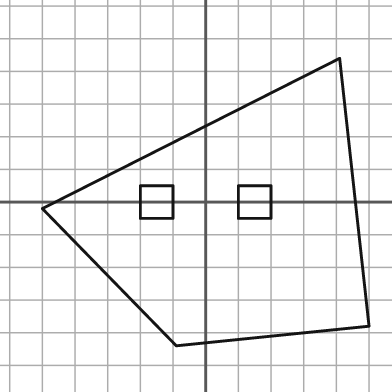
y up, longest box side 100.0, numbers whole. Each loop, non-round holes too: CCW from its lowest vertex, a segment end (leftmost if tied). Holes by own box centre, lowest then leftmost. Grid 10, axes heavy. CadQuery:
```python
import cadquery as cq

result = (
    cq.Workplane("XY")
    .moveTo(-9.0, -44.0)
    .lineTo(50.0, -38.0)
    .lineTo(41.0, 44.0)
    .lineTo(-50.0, -2.0)
    .close()
    .moveTo(-20.0, -5.0)
    .lineTo(-10.0, -5.0)
    .lineTo(-10.0, 5.0)
    .lineTo(-20.0, 5.0)
    .close()
    .moveTo(10.0, -5.0)
    .lineTo(20.0, -5.0)
    .lineTo(20.0, 5.0)
    .lineTo(10.0, 5.0)
    .close()
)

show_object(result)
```